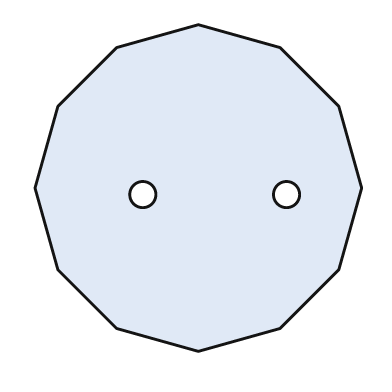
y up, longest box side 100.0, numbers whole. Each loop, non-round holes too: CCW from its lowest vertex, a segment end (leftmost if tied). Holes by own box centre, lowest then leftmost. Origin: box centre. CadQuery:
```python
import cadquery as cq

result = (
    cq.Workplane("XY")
    .moveTo(0.0, -50.0)
    .lineTo(25.0, -43.0)
    .lineTo(43.0, -25.0)
    .lineTo(50.0, 0.0)
    .lineTo(43.0, 25.0)
    .lineTo(25.0, 43.0)
    .lineTo(0.0, 50.0)
    .lineTo(-25.0, 43.0)
    .lineTo(-43.0, 25.0)
    .lineTo(-50.0, 0.0)
    .lineTo(-43.0, -25.0)
    .lineTo(-25.0, -43.0)
    .close()
    .moveTo(-17.0, -2.0)
    .circle(4.0)
    .moveTo(27.0, -2.0)
    .circle(4.0)
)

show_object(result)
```